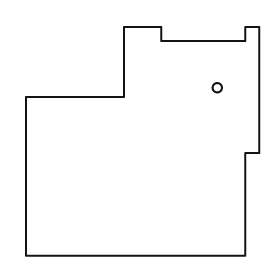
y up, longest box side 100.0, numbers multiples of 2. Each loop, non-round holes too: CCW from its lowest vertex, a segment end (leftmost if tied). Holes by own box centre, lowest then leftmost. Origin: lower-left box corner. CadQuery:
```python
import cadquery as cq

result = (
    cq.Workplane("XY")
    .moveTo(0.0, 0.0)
    .lineTo(94.0, 0.0)
    .lineTo(94.0, 44.0)
    .lineTo(100.0, 44.0)
    .lineTo(100.0, 98.0)
    .lineTo(94.0, 98.0)
    .lineTo(94.0, 92.0)
    .lineTo(58.0, 92.0)
    .lineTo(58.0, 98.0)
    .lineTo(42.0, 98.0)
    .lineTo(42.0, 68.0)
    .lineTo(0.0, 68.0)
    .close()
    .moveTo(82.0, 72.0)
    .circle(2.0)
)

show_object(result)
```